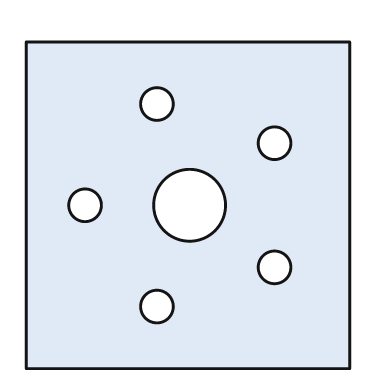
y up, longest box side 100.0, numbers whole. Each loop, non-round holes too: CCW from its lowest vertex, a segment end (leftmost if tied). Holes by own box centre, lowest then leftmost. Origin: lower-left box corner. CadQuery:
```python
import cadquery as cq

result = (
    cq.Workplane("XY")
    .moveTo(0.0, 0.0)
    .lineTo(99.0, 0.0)
    .lineTo(99.0, 100.0)
    .lineTo(0.0, 100.0)
    .close()
    .moveTo(40.0, 19.0)
    .circle(5.0)
    .moveTo(76.0, 31.0)
    .circle(5.0)
    .moveTo(18.0, 50.0)
    .circle(5.0)
    .moveTo(50.0, 50.0)
    .circle(11.0)
    .moveTo(76.0, 69.0)
    .circle(5.0)
    .moveTo(40.0, 81.0)
    .circle(5.0)
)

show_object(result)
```